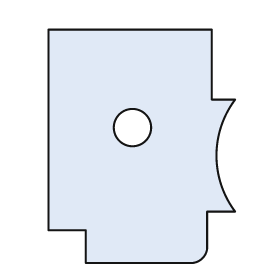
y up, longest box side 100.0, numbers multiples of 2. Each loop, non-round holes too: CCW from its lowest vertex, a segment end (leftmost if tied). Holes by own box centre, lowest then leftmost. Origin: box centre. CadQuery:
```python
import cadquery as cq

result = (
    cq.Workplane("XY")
    .moveTo(-24.0, -50.0)
    .lineTo(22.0, -50.0)
    .threePointArc((26.0, -48.0), (28.0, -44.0))
    .lineTo(28.0, -28.0)
    .lineTo(40.0, -28.0)
    .threePointArc((32.0, -4.0), (40.0, 20.0))
    .lineTo(30.0, 20.0)
    .lineTo(30.0, 50.0)
    .lineTo(-40.0, 50.0)
    .lineTo(-40.0, -36.0)
    .lineTo(-24.0, -36.0)
    .close()
    .moveTo(-4.0, 8.0)
    .circle(8.0)
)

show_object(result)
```